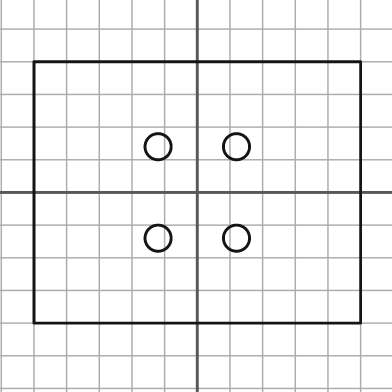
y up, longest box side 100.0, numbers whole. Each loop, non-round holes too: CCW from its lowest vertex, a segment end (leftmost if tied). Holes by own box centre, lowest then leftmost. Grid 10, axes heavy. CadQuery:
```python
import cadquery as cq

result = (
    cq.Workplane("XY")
    .moveTo(-50.0, -40.0)
    .lineTo(50.0, -40.0)
    .lineTo(50.0, 40.0)
    .lineTo(-50.0, 40.0)
    .close()
    .moveTo(-12.0, -14.0)
    .circle(4.0)
    .moveTo(12.0, -14.0)
    .circle(4.0)
    .moveTo(-12.0, 14.0)
    .circle(4.0)
    .moveTo(12.0, 14.0)
    .circle(4.0)
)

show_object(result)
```